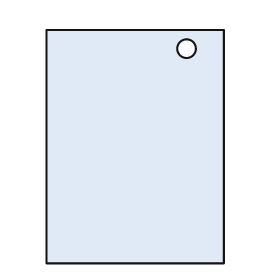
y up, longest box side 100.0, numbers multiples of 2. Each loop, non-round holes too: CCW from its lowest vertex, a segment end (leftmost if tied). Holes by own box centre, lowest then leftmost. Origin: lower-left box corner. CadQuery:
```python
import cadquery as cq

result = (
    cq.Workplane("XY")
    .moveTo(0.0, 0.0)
    .lineTo(76.0, 0.0)
    .lineTo(76.0, 100.0)
    .lineTo(0.0, 100.0)
    .close()
    .moveTo(60.0, 92.0)
    .circle(4.0)
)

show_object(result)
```